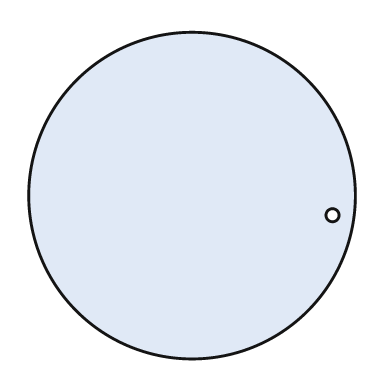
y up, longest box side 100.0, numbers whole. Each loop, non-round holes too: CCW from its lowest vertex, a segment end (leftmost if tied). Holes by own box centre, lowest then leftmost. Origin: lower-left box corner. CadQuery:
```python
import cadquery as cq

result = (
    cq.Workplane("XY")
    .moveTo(50.0, 50.0)
    .circle(50.0)
    .moveTo(93.0, 44.0)
    .circle(2.0)
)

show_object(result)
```